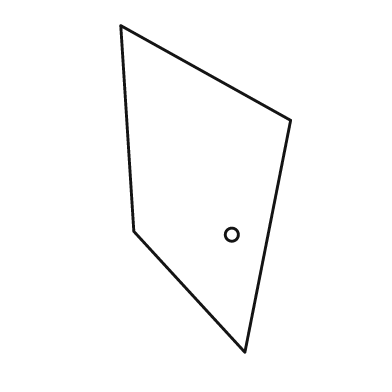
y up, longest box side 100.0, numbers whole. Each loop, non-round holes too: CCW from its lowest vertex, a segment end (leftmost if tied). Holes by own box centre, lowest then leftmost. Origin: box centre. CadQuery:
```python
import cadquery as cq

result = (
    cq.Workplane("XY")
    .moveTo(12.0, -50.0)
    .lineTo(26.0, 21.0)
    .lineTo(-26.0, 50.0)
    .lineTo(-22.0, -13.0)
    .close()
    .moveTo(8.0, -14.0)
    .circle(2.0)
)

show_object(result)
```